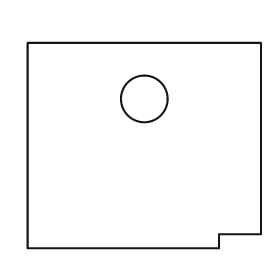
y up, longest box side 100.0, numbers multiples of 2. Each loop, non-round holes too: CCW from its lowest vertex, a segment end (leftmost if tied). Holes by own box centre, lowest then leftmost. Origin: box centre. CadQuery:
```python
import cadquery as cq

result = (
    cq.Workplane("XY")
    .moveTo(-50.0, -44.0)
    .lineTo(32.0, -44.0)
    .lineTo(32.0, -38.0)
    .lineTo(50.0, -38.0)
    .lineTo(50.0, 44.0)
    .lineTo(-50.0, 44.0)
    .close()
    .moveTo(0.0, 20.0)
    .circle(10.0)
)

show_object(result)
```